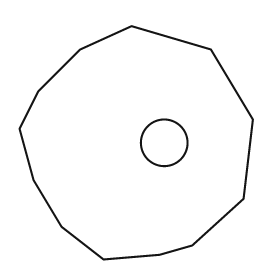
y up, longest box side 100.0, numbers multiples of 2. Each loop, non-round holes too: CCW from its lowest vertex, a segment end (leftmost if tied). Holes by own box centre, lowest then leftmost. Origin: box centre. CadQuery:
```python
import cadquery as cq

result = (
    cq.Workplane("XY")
    .moveTo(-14.0, -50.0)
    .lineTo(10.0, -48.0)
    .lineTo(24.0, -44.0)
    .lineTo(46.0, -24.0)
    .lineTo(50.0, 10.0)
    .lineTo(32.0, 40.0)
    .lineTo(-2.0, 50.0)
    .lineTo(-24.0, 40.0)
    .lineTo(-42.0, 22.0)
    .lineTo(-50.0, 6.0)
    .lineTo(-44.0, -16.0)
    .lineTo(-32.0, -36.0)
    .close()
    .moveTo(12.0, 0.0)
    .circle(10.0)
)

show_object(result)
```